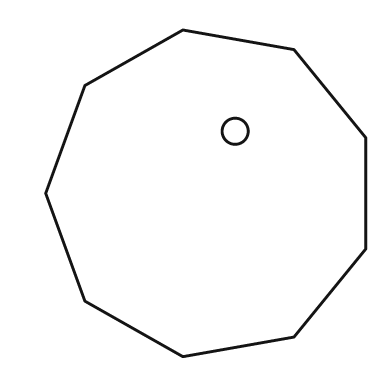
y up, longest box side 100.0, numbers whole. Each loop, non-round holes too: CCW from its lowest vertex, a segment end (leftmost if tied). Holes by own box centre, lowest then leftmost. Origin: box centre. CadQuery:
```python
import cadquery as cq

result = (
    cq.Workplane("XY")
    .moveTo(-7.0, -50.0)
    .lineTo(27.0, -44.0)
    .lineTo(49.0, -17.0)
    .lineTo(49.0, 17.0)
    .lineTo(27.0, 44.0)
    .lineTo(-7.0, 50.0)
    .lineTo(-37.0, 33.0)
    .lineTo(-49.0, 0.0)
    .lineTo(-37.0, -33.0)
    .close()
    .moveTo(9.0, 19.0)
    .circle(4.0)
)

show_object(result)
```